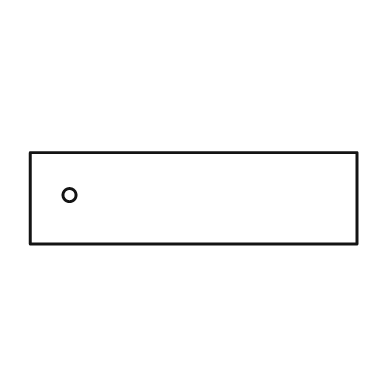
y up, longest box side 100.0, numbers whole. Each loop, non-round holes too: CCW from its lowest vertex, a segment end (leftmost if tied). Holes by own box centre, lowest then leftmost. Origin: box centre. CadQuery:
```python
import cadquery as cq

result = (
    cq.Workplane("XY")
    .moveTo(-50.0, -14.0)
    .lineTo(50.0, -14.0)
    .lineTo(50.0, 14.0)
    .lineTo(-50.0, 14.0)
    .close()
    .moveTo(-38.0, 1.0)
    .circle(2.0)
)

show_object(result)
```